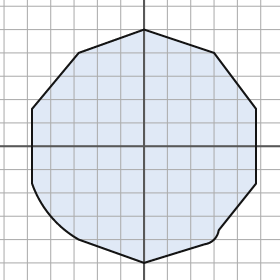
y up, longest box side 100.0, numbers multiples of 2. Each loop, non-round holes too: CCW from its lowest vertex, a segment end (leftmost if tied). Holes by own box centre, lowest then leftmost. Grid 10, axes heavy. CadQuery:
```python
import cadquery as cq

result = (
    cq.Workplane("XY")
    .moveTo(0.0, -50.0)
    .lineTo(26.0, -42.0)
    .threePointArc((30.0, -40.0), (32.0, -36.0))
    .lineTo(48.0, -16.0)
    .lineTo(48.0, 16.0)
    .lineTo(30.0, 40.0)
    .lineTo(0.0, 50.0)
    .lineTo(-28.0, 40.0)
    .lineTo(-48.0, 16.0)
    .lineTo(-48.0, -16.0)
    .threePointArc((-40.0, -30.0), (-28.0, -40.0))
    .close()
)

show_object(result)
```